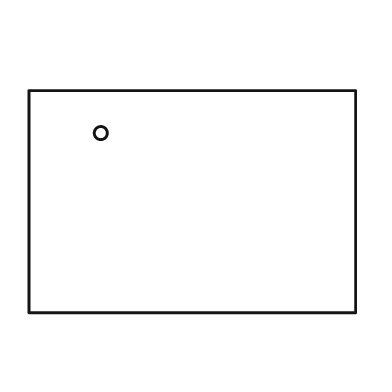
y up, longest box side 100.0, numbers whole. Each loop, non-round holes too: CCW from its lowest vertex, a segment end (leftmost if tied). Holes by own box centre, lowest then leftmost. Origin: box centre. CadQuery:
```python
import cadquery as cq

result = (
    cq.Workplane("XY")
    .moveTo(-50.0, -34.0)
    .lineTo(50.0, -34.0)
    .lineTo(50.0, 34.0)
    .lineTo(-50.0, 34.0)
    .close()
    .moveTo(-28.0, 21.0)
    .circle(2.0)
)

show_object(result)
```